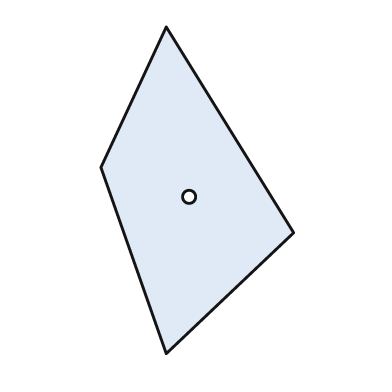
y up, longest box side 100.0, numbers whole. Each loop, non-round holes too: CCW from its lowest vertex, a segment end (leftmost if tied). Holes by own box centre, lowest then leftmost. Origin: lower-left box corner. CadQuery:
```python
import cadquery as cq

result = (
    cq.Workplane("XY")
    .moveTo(20.0, 0.0)
    .lineTo(59.0, 37.0)
    .lineTo(20.0, 100.0)
    .lineTo(0.0, 57.0)
    .close()
    .moveTo(27.0, 48.0)
    .circle(2.0)
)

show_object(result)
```